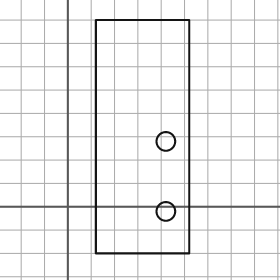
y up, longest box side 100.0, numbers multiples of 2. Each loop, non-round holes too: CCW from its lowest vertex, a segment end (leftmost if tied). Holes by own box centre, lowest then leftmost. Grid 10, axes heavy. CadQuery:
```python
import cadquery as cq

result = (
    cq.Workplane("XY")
    .moveTo(12.0, -20.0)
    .lineTo(52.0, -20.0)
    .lineTo(52.0, 80.0)
    .lineTo(12.0, 80.0)
    .close()
    .moveTo(42.0, -2.0)
    .circle(4.0)
    .moveTo(42.0, 28.0)
    .circle(4.0)
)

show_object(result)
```